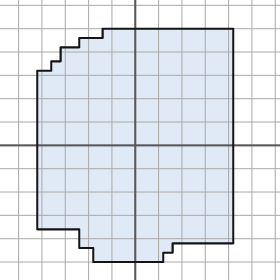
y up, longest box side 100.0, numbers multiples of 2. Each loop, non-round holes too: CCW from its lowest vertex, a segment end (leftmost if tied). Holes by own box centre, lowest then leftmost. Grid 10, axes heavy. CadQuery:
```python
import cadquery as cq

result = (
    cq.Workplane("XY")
    .moveTo(-18.0, -50.0)
    .lineTo(12.0, -50.0)
    .lineTo(12.0, -46.0)
    .lineTo(16.0, -46.0)
    .lineTo(16.0, -42.0)
    .lineTo(42.0, -42.0)
    .lineTo(42.0, 50.0)
    .lineTo(-14.0, 50.0)
    .lineTo(-14.0, 46.0)
    .lineTo(-24.0, 46.0)
    .lineTo(-24.0, 42.0)
    .lineTo(-32.0, 42.0)
    .lineTo(-32.0, 36.0)
    .lineTo(-36.0, 36.0)
    .lineTo(-36.0, 32.0)
    .lineTo(-42.0, 32.0)
    .lineTo(-42.0, -36.0)
    .lineTo(-24.0, -36.0)
    .lineTo(-24.0, -44.0)
    .lineTo(-18.0, -44.0)
    .close()
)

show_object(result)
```